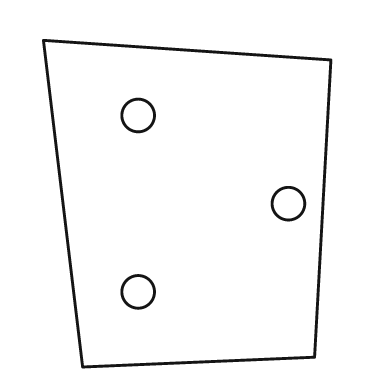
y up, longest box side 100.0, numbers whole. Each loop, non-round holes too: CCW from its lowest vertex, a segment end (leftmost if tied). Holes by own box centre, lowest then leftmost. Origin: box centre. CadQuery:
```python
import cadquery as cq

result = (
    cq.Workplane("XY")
    .moveTo(-32.0, -50.0)
    .lineTo(39.0, -47.0)
    .lineTo(44.0, 44.0)
    .lineTo(-44.0, 50.0)
    .close()
    .moveTo(-15.0, -27.0)
    .circle(5.0)
    .moveTo(31.0, 0.0)
    .circle(5.0)
    .moveTo(-15.0, 27.0)
    .circle(5.0)
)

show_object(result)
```